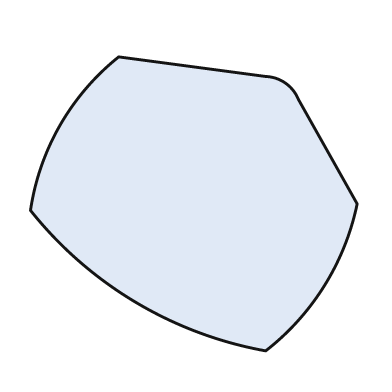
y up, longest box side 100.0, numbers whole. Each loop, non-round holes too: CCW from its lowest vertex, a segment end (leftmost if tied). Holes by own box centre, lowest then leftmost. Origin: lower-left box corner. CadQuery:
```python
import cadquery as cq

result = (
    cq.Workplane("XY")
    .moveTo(72.0, 0.0)
    .threePointArc((90.0, 20.0), (100.0, 45.0))
    .lineTo(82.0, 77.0)
    .threePointArc((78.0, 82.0), (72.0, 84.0))
    .lineTo(27.0, 90.0)
    .threePointArc((9.0, 69.0), (0.0, 43.0))
    .threePointArc((32.0, 15.0), (72.0, 0.0))
    .close()
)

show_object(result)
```